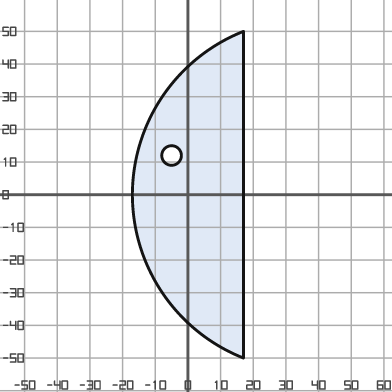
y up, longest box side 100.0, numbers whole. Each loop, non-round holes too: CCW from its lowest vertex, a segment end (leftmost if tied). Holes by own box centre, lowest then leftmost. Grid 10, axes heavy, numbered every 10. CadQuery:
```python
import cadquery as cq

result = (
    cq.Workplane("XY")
    .moveTo(17.0, -50.0)
    .lineTo(17.0, 50.0)
    .threePointArc((-17.0, 0.0), (17.0, -50.0))
    .close()
    .moveTo(-5.0, 12.0)
    .circle(3.0)
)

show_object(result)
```